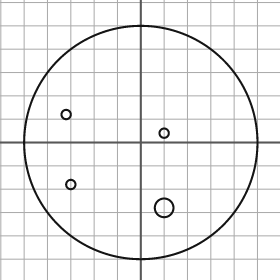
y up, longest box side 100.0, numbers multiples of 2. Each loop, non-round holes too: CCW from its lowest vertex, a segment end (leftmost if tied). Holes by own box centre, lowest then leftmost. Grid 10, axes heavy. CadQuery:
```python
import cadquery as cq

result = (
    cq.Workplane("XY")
    .moveTo(0.0, 0.0)
    .circle(50.0)
    .moveTo(10.0, -28.0)
    .circle(4.0)
    .moveTo(-30.0, -18.0)
    .circle(2.0)
    .moveTo(10.0, 4.0)
    .circle(2.0)
    .moveTo(-32.0, 12.0)
    .circle(2.0)
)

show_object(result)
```